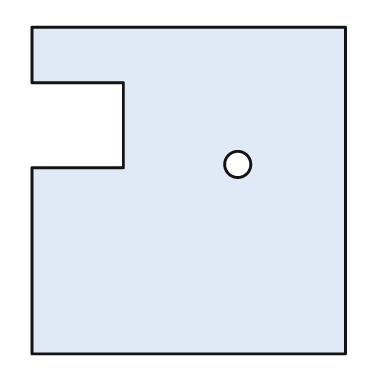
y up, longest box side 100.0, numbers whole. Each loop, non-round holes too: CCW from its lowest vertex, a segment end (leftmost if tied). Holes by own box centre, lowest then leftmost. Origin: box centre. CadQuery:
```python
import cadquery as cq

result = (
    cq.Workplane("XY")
    .moveTo(-48.0, -50.0)
    .lineTo(48.0, -50.0)
    .lineTo(48.0, 50.0)
    .lineTo(-48.0, 50.0)
    .lineTo(-48.0, 33.0)
    .lineTo(-20.0, 33.0)
    .lineTo(-20.0, 7.0)
    .lineTo(-48.0, 7.0)
    .close()
    .moveTo(15.0, 8.0)
    .circle(4.0)
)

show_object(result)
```